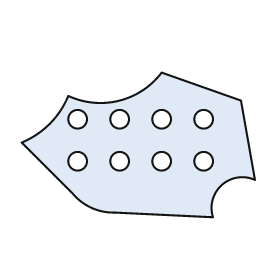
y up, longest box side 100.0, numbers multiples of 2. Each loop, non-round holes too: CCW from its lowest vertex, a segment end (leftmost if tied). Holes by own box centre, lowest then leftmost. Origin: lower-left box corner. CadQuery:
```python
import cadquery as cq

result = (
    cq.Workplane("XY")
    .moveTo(82.0, 0.0)
    .threePointArc((86.0, 14.0), (100.0, 16.0))
    .lineTo(94.0, 50.0)
    .lineTo(60.0, 62.0)
    .threePointArc((42.0, 50.0), (20.0, 52.0))
    .threePointArc((12.0, 40.0), (0.0, 32.0))
    .lineTo(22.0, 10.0)
    .threePointArc((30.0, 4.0), (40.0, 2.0))
    .close()
    .moveTo(24.0, 24.0)
    .circle(4.0)
    .moveTo(42.0, 24.0)
    .circle(4.0)
    .moveTo(60.0, 24.0)
    .circle(4.0)
    .moveTo(78.0, 24.0)
    .circle(4.0)
    .moveTo(24.0, 42.0)
    .circle(4.0)
    .moveTo(42.0, 42.0)
    .circle(4.0)
    .moveTo(60.0, 42.0)
    .circle(4.0)
    .moveTo(78.0, 42.0)
    .circle(4.0)
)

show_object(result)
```